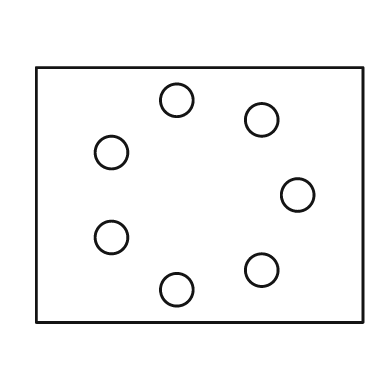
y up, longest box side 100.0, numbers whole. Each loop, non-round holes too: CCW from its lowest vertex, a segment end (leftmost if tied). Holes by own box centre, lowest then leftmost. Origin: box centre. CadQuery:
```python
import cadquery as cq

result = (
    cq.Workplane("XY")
    .moveTo(-50.0, -39.0)
    .lineTo(50.0, -39.0)
    .lineTo(50.0, 39.0)
    .lineTo(-50.0, 39.0)
    .close()
    .moveTo(-7.0, -29.0)
    .circle(5.0)
    .moveTo(19.0, -23.0)
    .circle(5.0)
    .moveTo(-27.0, -13.0)
    .circle(5.0)
    .moveTo(30.0, 0.0)
    .circle(5.0)
    .moveTo(-27.0, 13.0)
    .circle(5.0)
    .moveTo(19.0, 23.0)
    .circle(5.0)
    .moveTo(-7.0, 29.0)
    .circle(5.0)
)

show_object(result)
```